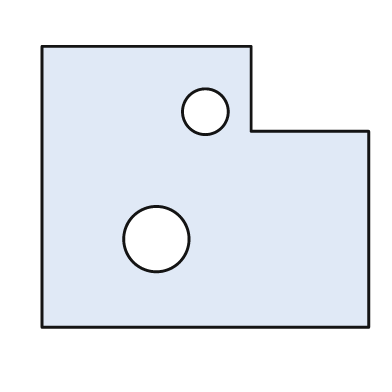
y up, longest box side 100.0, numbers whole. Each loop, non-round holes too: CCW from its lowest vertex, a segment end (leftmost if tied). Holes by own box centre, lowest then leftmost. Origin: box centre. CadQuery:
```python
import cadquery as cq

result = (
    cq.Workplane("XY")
    .moveTo(-50.0, -43.0)
    .lineTo(50.0, -43.0)
    .lineTo(50.0, 17.0)
    .lineTo(14.0, 17.0)
    .lineTo(14.0, 43.0)
    .lineTo(-50.0, 43.0)
    .close()
    .moveTo(-15.0, -16.0)
    .circle(10.0)
    .moveTo(0.0, 23.0)
    .circle(7.0)
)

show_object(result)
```